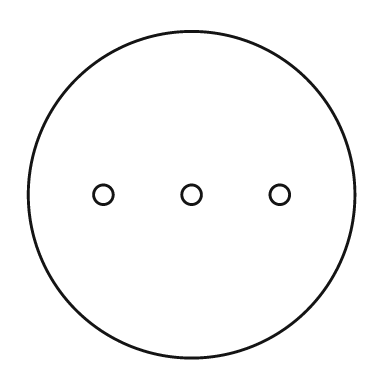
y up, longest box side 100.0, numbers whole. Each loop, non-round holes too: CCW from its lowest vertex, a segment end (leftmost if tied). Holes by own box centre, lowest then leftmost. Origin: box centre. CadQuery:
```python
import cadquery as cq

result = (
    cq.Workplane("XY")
    .moveTo(0.0, 0.0)
    .circle(50.0)
    .moveTo(-27.0, 0.0)
    .circle(3.0)
    .moveTo(0.0, 0.0)
    .circle(3.0)
    .moveTo(27.0, 0.0)
    .circle(3.0)
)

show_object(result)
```